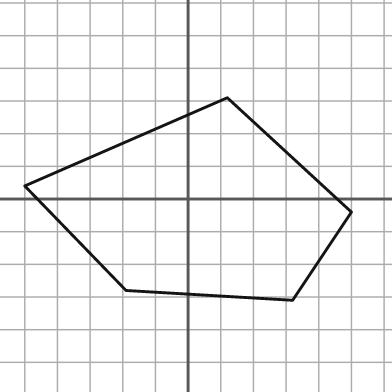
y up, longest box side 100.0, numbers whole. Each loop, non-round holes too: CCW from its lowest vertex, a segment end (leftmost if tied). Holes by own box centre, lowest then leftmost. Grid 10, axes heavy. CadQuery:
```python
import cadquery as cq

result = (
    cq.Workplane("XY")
    .moveTo(32.0, -31.0)
    .lineTo(50.0, -4.0)
    .lineTo(12.0, 31.0)
    .lineTo(-50.0, 4.0)
    .lineTo(-19.0, -28.0)
    .close()
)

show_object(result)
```